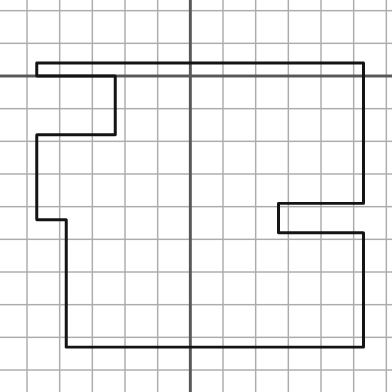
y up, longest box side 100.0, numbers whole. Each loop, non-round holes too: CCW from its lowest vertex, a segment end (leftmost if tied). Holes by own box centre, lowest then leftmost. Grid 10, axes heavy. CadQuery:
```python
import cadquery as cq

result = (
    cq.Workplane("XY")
    .moveTo(-38.0, -83.0)
    .lineTo(53.0, -83.0)
    .lineTo(53.0, -48.0)
    .lineTo(27.0, -48.0)
    .lineTo(27.0, -39.0)
    .lineTo(53.0, -39.0)
    .lineTo(53.0, 4.0)
    .lineTo(-47.0, 4.0)
    .lineTo(-47.0, 0.0)
    .lineTo(-23.0, 0.0)
    .lineTo(-23.0, -18.0)
    .lineTo(-47.0, -18.0)
    .lineTo(-47.0, -44.0)
    .lineTo(-38.0, -44.0)
    .close()
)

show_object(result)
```